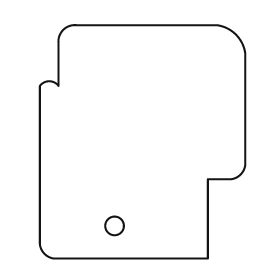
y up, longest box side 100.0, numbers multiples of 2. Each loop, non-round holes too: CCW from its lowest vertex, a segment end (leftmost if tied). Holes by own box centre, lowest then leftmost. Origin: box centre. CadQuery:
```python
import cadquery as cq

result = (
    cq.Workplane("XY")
    .moveTo(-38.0, -50.0)
    .lineTo(28.0, -50.0)
    .lineTo(28.0, -16.0)
    .lineTo(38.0, -16.0)
    .threePointArc((42.0, -14.0), (44.0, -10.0))
    .lineTo(44.0, 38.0)
    .threePointArc((40.0, 46.0), (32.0, 50.0))
    .lineTo(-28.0, 50.0)
    .threePointArc((-34.0, 48.0), (-36.0, 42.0))
    .lineTo(-36.0, 24.0)
    .threePointArc((-40.0, 26.0), (-44.0, 24.0))
    .lineTo(-44.0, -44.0)
    .threePointArc((-42.0, -48.0), (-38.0, -50.0))
    .close()
    .moveTo(-12.0, -36.0)
    .circle(4.0)
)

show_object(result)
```